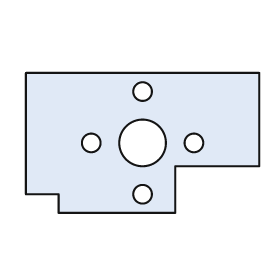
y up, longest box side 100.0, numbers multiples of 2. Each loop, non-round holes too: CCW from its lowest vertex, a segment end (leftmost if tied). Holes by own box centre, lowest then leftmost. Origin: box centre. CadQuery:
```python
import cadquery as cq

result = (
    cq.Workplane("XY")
    .moveTo(-36.0, -30.0)
    .lineTo(14.0, -30.0)
    .lineTo(14.0, -10.0)
    .lineTo(50.0, -10.0)
    .lineTo(50.0, 30.0)
    .lineTo(-50.0, 30.0)
    .lineTo(-50.0, -22.0)
    .lineTo(-36.0, -22.0)
    .close()
    .moveTo(0.0, -22.0)
    .circle(4.0)
    .moveTo(-22.0, 0.0)
    .circle(4.0)
    .moveTo(0.0, 0.0)
    .circle(10.0)
    .moveTo(22.0, 0.0)
    .circle(4.0)
    .moveTo(0.0, 22.0)
    .circle(4.0)
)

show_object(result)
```